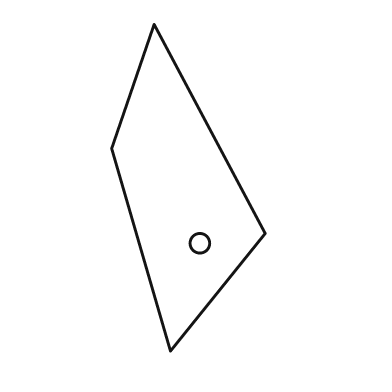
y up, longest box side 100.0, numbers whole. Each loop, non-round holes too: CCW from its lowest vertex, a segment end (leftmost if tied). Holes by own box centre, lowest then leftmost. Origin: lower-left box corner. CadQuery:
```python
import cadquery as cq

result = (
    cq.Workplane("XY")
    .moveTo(18.0, 0.0)
    .lineTo(47.0, 36.0)
    .lineTo(13.0, 100.0)
    .lineTo(0.0, 62.0)
    .close()
    .moveTo(27.0, 33.0)
    .circle(3.0)
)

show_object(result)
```